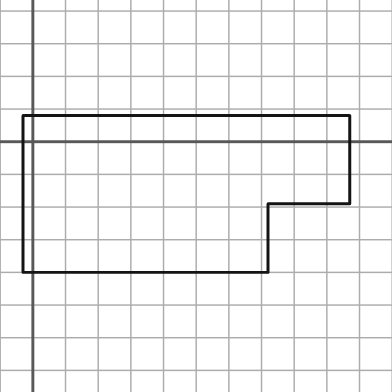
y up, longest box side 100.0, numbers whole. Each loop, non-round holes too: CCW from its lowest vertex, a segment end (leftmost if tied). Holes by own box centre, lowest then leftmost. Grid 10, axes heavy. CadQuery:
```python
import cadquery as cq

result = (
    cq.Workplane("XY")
    .moveTo(-3.0, -40.0)
    .lineTo(72.0, -40.0)
    .lineTo(72.0, -19.0)
    .lineTo(97.0, -19.0)
    .lineTo(97.0, 8.0)
    .lineTo(-3.0, 8.0)
    .close()
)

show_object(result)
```